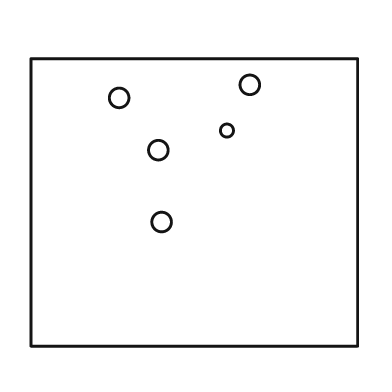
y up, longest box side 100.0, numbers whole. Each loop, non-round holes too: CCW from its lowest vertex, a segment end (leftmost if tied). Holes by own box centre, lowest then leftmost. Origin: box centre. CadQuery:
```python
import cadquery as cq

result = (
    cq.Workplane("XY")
    .moveTo(-50.0, -44.0)
    .lineTo(50.0, -44.0)
    .lineTo(50.0, 44.0)
    .lineTo(-50.0, 44.0)
    .close()
    .moveTo(-10.0, -6.0)
    .circle(3.0)
    .moveTo(-11.0, 16.0)
    .circle(3.0)
    .moveTo(10.0, 22.0)
    .circle(2.0)
    .moveTo(-23.0, 32.0)
    .circle(3.0)
    .moveTo(17.0, 36.0)
    .circle(3.0)
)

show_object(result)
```